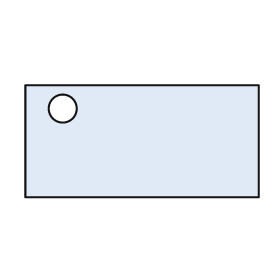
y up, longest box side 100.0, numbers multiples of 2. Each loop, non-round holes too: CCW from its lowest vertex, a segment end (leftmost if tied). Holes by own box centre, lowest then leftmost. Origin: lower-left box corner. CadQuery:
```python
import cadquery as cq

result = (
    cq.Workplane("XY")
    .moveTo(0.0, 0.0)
    .lineTo(100.0, 0.0)
    .lineTo(100.0, 48.0)
    .lineTo(0.0, 48.0)
    .close()
    .moveTo(16.0, 38.0)
    .circle(6.0)
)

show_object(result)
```